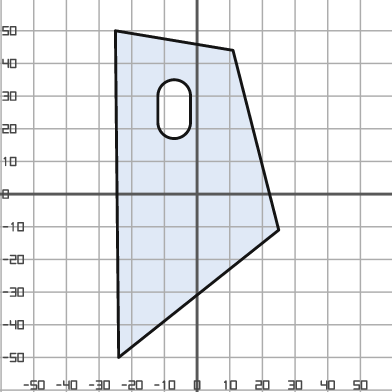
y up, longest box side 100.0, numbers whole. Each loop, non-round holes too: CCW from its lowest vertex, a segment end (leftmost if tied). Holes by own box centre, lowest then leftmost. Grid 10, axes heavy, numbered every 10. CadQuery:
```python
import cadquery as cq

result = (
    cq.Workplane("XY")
    .moveTo(-24.0, -50.0)
    .lineTo(25.0, -11.0)
    .lineTo(11.0, 44.0)
    .lineTo(-25.0, 50.0)
    .close()
    .moveTo(-12.0, 22.0)
    .threePointArc((-7.0, 17.0), (-2.0, 22.0))
    .lineTo(-2.0, 30.0)
    .threePointArc((-7.0, 35.0), (-12.0, 30.0))
    .close()
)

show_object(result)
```